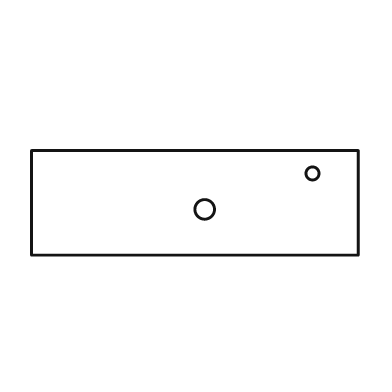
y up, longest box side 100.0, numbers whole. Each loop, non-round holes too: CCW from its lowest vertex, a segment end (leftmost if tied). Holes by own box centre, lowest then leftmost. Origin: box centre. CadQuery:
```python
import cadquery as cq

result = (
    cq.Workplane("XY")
    .moveTo(-50.0, -16.0)
    .lineTo(50.0, -16.0)
    .lineTo(50.0, 16.0)
    .lineTo(-50.0, 16.0)
    .close()
    .moveTo(3.0, -2.0)
    .circle(3.0)
    .moveTo(36.0, 9.0)
    .circle(2.0)
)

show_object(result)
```